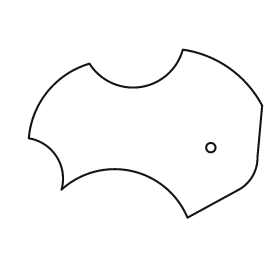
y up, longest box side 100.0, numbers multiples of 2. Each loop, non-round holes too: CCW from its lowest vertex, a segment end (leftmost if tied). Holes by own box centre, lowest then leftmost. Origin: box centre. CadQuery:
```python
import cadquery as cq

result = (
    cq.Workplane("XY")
    .moveTo(18.0, -36.0)
    .lineTo(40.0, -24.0)
    .threePointArc((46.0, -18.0), (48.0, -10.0))
    .lineTo(50.0, 12.0)
    .threePointArc((36.0, 28.0), (16.0, 36.0))
    .threePointArc((-2.0, 20.0), (-24.0, 30.0))
    .threePointArc((-42.0, 18.0), (-50.0, -2.0))
    .threePointArc((-38.0, -10.0), (-36.0, -24.0))
    .threePointArc((-6.0, -16.0), (18.0, -36.0))
    .close()
    .moveTo(28.0, -6.0)
    .circle(2.0)
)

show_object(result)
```